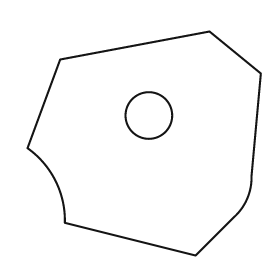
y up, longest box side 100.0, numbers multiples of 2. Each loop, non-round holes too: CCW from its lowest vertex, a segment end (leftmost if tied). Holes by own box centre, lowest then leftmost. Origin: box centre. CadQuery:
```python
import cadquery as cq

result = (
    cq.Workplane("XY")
    .moveTo(22.0, -48.0)
    .lineTo(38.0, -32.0)
    .threePointArc((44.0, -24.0), (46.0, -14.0))
    .lineTo(50.0, 30.0)
    .lineTo(28.0, 48.0)
    .lineTo(-36.0, 36.0)
    .lineTo(-50.0, -2.0)
    .threePointArc((-38.0, -16.0), (-34.0, -34.0))
    .close()
    .moveTo(2.0, 12.0)
    .circle(10.0)
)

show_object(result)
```